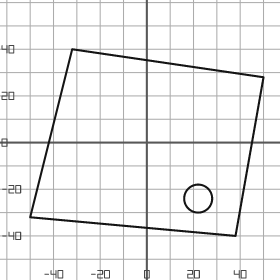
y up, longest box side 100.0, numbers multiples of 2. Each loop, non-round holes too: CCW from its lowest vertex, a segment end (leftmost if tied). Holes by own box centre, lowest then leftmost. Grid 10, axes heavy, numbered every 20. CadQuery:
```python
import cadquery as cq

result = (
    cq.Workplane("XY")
    .moveTo(38.0, -40.0)
    .lineTo(50.0, 28.0)
    .lineTo(-32.0, 40.0)
    .lineTo(-50.0, -32.0)
    .close()
    .moveTo(22.0, -24.0)
    .circle(6.0)
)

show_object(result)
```